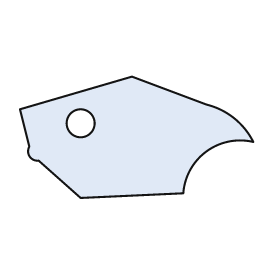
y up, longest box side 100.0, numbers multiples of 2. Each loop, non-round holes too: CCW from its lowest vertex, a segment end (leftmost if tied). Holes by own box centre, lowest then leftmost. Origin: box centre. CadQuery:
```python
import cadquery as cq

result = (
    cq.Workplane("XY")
    .moveTo(-24.0, -26.0)
    .lineTo(20.0, -24.0)
    .threePointArc((30.0, -6.0), (50.0, -2.0))
    .threePointArc((42.0, 8.0), (30.0, 14.0))
    .lineTo(-2.0, 26.0)
    .lineTo(-50.0, 12.0)
    .lineTo(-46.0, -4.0)
    .threePointArc((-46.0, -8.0), (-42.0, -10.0))
    .close()
    .moveTo(-24.0, 6.0)
    .circle(6.0)
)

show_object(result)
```